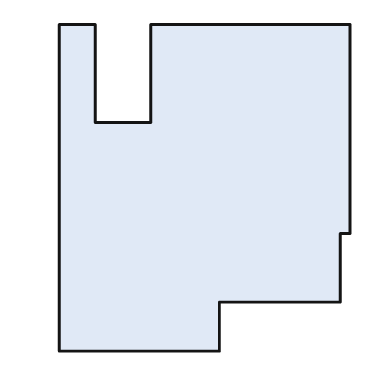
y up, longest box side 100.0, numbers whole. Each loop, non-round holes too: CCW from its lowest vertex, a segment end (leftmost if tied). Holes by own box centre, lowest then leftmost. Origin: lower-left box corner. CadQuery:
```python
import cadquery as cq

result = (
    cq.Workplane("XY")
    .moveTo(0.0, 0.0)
    .lineTo(49.0, 0.0)
    .lineTo(49.0, 15.0)
    .lineTo(86.0, 15.0)
    .lineTo(86.0, 36.0)
    .lineTo(89.0, 36.0)
    .lineTo(89.0, 100.0)
    .lineTo(28.0, 100.0)
    .lineTo(28.0, 70.0)
    .lineTo(11.0, 70.0)
    .lineTo(11.0, 100.0)
    .lineTo(0.0, 100.0)
    .close()
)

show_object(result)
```